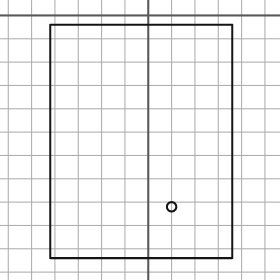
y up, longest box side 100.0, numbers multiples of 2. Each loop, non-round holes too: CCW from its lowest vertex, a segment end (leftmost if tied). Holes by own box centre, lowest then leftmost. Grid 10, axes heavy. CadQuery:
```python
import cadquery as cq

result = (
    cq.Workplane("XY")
    .moveTo(-42.0, -104.0)
    .lineTo(36.0, -104.0)
    .lineTo(36.0, -4.0)
    .lineTo(-42.0, -4.0)
    .close()
    .moveTo(10.0, -82.0)
    .circle(2.0)
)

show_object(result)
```